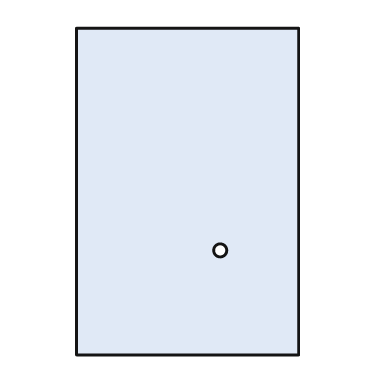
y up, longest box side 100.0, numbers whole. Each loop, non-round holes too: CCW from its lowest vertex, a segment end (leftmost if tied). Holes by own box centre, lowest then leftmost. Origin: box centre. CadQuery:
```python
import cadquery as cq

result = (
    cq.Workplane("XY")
    .moveTo(-34.0, -50.0)
    .lineTo(34.0, -50.0)
    .lineTo(34.0, 50.0)
    .lineTo(-34.0, 50.0)
    .close()
    .moveTo(10.0, -18.0)
    .circle(2.0)
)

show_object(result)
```